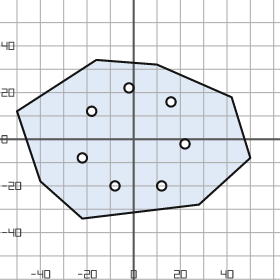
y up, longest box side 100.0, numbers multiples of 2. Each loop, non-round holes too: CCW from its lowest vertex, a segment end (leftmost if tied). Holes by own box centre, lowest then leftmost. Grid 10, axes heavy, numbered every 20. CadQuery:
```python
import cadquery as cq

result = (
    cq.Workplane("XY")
    .moveTo(-22.0, -34.0)
    .lineTo(28.0, -28.0)
    .lineTo(50.0, -8.0)
    .lineTo(42.0, 18.0)
    .lineTo(10.0, 32.0)
    .lineTo(-16.0, 34.0)
    .lineTo(-50.0, 12.0)
    .lineTo(-40.0, -18.0)
    .close()
    .moveTo(-8.0, -20.0)
    .circle(2.0)
    .moveTo(12.0, -20.0)
    .circle(2.0)
    .moveTo(-22.0, -8.0)
    .circle(2.0)
    .moveTo(22.0, -2.0)
    .circle(2.0)
    .moveTo(-18.0, 12.0)
    .circle(2.0)
    .moveTo(16.0, 16.0)
    .circle(2.0)
    .moveTo(-2.0, 22.0)
    .circle(2.0)
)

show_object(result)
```